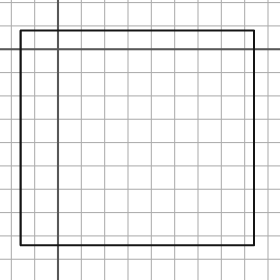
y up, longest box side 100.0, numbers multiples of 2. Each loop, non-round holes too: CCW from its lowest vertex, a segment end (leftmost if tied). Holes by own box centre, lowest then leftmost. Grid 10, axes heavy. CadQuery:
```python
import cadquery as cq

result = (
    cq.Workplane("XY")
    .moveTo(-16.0, -84.0)
    .lineTo(84.0, -84.0)
    .lineTo(84.0, 8.0)
    .lineTo(-16.0, 8.0)
    .close()
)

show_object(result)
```